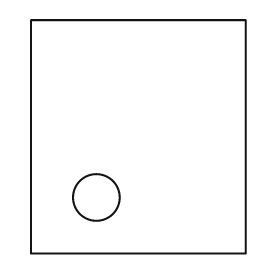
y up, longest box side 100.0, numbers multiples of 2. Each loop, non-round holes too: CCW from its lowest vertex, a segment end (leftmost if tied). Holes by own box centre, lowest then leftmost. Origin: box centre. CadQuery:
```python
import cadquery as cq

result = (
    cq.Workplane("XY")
    .moveTo(-46.0, -50.0)
    .lineTo(46.0, -50.0)
    .lineTo(46.0, 50.0)
    .lineTo(-46.0, 50.0)
    .close()
    .moveTo(-18.0, -26.0)
    .circle(10.0)
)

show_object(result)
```